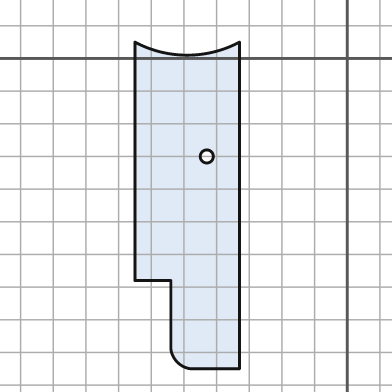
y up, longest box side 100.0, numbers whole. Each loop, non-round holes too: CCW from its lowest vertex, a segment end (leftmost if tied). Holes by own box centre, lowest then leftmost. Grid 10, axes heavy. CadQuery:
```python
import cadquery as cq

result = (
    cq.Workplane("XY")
    .moveTo(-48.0, -95.0)
    .lineTo(-33.0, -95.0)
    .lineTo(-33.0, 5.0)
    .threePointArc((-49.0, 1.0), (-65.0, 5.0))
    .lineTo(-65.0, -68.0)
    .lineTo(-54.0, -68.0)
    .lineTo(-54.0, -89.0)
    .threePointArc((-52.0, -93.0), (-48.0, -95.0))
    .close()
    .moveTo(-43.0, -30.0)
    .circle(2.0)
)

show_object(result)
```